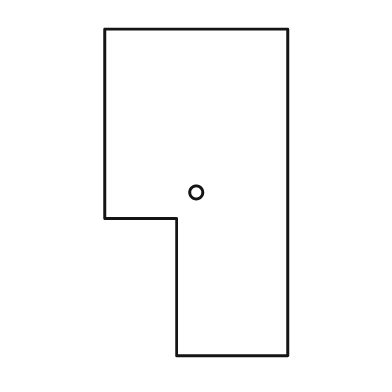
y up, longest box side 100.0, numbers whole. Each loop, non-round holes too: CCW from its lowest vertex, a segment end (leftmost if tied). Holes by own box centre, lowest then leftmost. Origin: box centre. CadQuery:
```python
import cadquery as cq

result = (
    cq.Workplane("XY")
    .moveTo(-6.0, -50.0)
    .lineTo(28.0, -50.0)
    .lineTo(28.0, 50.0)
    .lineTo(-28.0, 50.0)
    .lineTo(-28.0, -8.0)
    .lineTo(-6.0, -8.0)
    .close()
    .moveTo(0.0, 0.0)
    .circle(2.0)
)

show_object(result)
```